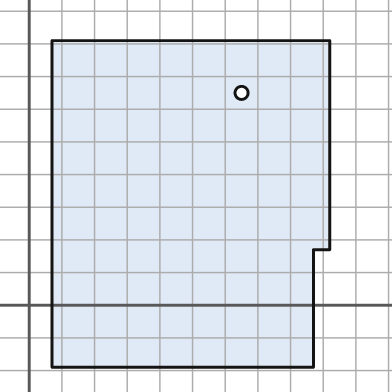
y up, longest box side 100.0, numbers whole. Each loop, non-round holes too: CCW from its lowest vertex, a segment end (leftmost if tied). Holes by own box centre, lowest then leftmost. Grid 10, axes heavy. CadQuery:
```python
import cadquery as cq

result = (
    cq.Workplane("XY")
    .moveTo(7.0, -19.0)
    .lineTo(87.0, -19.0)
    .lineTo(87.0, 17.0)
    .lineTo(92.0, 17.0)
    .lineTo(92.0, 81.0)
    .lineTo(7.0, 81.0)
    .close()
    .moveTo(65.0, 65.0)
    .circle(2.0)
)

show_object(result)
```